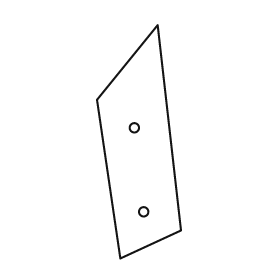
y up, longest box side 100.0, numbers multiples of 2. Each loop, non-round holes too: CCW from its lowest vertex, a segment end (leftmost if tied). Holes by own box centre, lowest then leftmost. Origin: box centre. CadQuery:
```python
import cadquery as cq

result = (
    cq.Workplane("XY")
    .moveTo(-8.0, -50.0)
    .lineTo(18.0, -38.0)
    .lineTo(8.0, 50.0)
    .lineTo(-18.0, 18.0)
    .close()
    .moveTo(2.0, -30.0)
    .circle(2.0)
    .moveTo(-2.0, 6.0)
    .circle(2.0)
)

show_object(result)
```